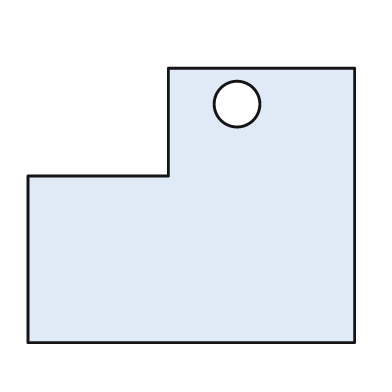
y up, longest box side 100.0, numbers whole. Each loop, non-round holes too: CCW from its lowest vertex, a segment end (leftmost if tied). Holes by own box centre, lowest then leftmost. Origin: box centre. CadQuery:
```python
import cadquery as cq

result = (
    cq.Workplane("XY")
    .moveTo(-50.0, -42.0)
    .lineTo(50.0, -42.0)
    .lineTo(50.0, 42.0)
    .lineTo(-7.0, 42.0)
    .lineTo(-7.0, 9.0)
    .lineTo(-50.0, 9.0)
    .close()
    .moveTo(14.0, 31.0)
    .circle(7.0)
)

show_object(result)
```